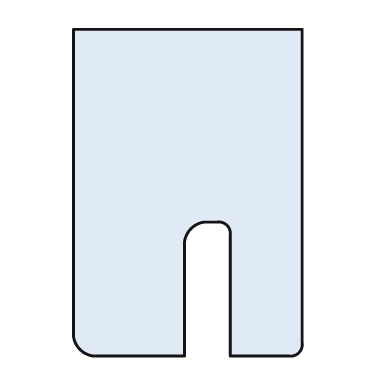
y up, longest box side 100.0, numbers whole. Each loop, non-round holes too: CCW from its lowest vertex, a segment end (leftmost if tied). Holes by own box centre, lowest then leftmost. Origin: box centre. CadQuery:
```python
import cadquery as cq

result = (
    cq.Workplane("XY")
    .moveTo(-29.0, -50.0)
    .lineTo(-1.0, -50.0)
    .lineTo(-1.0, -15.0)
    .threePointArc((1.0, -11.0), (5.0, -9.0))
    .lineTo(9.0, -9.0)
    .threePointArc((12.0, -10.0), (13.0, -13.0))
    .lineTo(13.0, -50.0)
    .lineTo(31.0, -50.0)
    .threePointArc((34.0, -49.0), (35.0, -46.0))
    .lineTo(35.0, 50.0)
    .lineTo(-35.0, 50.0)
    .lineTo(-35.0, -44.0)
    .threePointArc((-33.0, -48.0), (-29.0, -50.0))
    .close()
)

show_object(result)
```